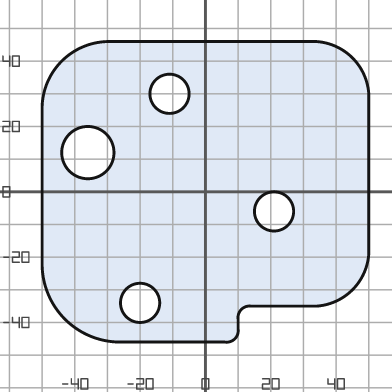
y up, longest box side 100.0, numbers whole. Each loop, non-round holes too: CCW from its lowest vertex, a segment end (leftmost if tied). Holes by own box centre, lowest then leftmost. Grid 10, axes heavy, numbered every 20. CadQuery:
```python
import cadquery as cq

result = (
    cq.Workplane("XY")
    .moveTo(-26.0, -46.0)
    .lineTo(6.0, -46.0)
    .threePointArc((9.0, -45.0), (10.0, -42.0))
    .lineTo(10.0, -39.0)
    .threePointArc((11.0, -36.0), (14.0, -35.0))
    .lineTo(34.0, -35.0)
    .threePointArc((45.0, -30.0), (50.0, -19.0))
    .lineTo(50.0, 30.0)
    .threePointArc((45.0, 41.0), (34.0, 46.0))
    .lineTo(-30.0, 46.0)
    .threePointArc((-44.0, 40.0), (-50.0, 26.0))
    .lineTo(-50.0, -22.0)
    .threePointArc((-43.0, -39.0), (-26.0, -46.0))
    .close()
    .moveTo(-20.0, -34.0)
    .circle(6.0)
    .moveTo(21.0, -6.0)
    .circle(6.0)
    .moveTo(-36.0, 12.0)
    .circle(8.0)
    .moveTo(-11.0, 30.0)
    .circle(6.0)
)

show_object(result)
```